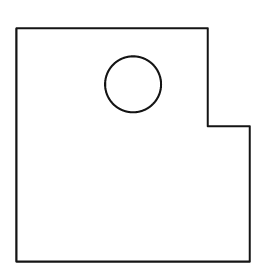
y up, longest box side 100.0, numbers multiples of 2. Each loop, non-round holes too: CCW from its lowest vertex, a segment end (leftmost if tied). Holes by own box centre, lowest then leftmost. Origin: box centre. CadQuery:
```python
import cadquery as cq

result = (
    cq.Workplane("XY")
    .moveTo(-50.0, -50.0)
    .lineTo(50.0, -50.0)
    .lineTo(50.0, 8.0)
    .lineTo(32.0, 8.0)
    .lineTo(32.0, 50.0)
    .lineTo(-50.0, 50.0)
    .close()
    .moveTo(0.0, 26.0)
    .circle(12.0)
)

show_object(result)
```